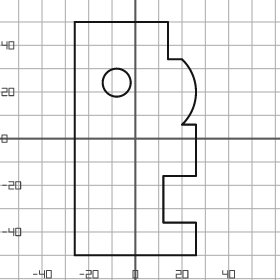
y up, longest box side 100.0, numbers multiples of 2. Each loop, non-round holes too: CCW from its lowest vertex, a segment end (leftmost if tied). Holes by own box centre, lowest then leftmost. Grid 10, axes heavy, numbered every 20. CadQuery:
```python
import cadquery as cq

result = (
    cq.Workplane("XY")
    .moveTo(-26.0, -50.0)
    .lineTo(26.0, -50.0)
    .lineTo(26.0, -36.0)
    .lineTo(12.0, -36.0)
    .lineTo(12.0, -16.0)
    .lineTo(26.0, -16.0)
    .lineTo(26.0, 6.0)
    .lineTo(20.0, 6.0)
    .threePointArc((26.0, 20.0), (20.0, 34.0))
    .lineTo(14.0, 34.0)
    .lineTo(14.0, 50.0)
    .lineTo(-26.0, 50.0)
    .close()
    .moveTo(-8.0, 24.0)
    .circle(6.0)
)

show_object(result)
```